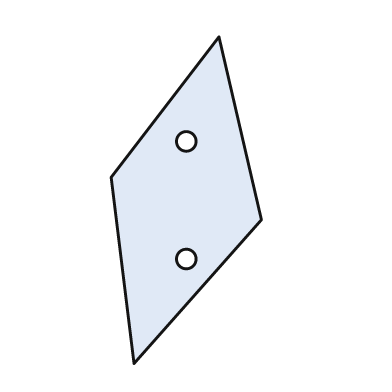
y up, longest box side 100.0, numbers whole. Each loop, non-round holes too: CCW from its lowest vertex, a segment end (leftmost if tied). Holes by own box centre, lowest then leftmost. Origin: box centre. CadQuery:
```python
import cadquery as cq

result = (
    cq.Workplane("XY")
    .moveTo(-16.0, -50.0)
    .lineTo(23.0, -6.0)
    .lineTo(10.0, 50.0)
    .lineTo(-23.0, 7.0)
    .close()
    .moveTo(0.0, -18.0)
    .circle(3.0)
    .moveTo(0.0, 18.0)
    .circle(3.0)
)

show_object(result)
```